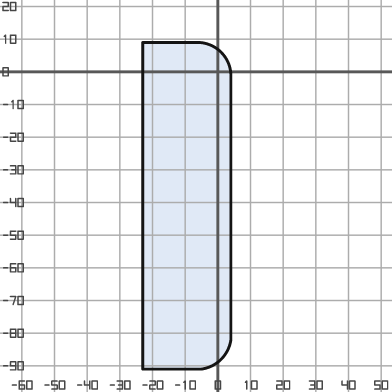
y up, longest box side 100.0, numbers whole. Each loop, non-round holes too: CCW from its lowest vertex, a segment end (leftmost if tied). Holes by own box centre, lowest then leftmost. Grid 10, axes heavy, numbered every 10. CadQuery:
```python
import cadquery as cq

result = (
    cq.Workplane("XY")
    .moveTo(-23.0, -91.0)
    .lineTo(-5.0, -91.0)
    .threePointArc((1.0, -88.0), (4.0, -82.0))
    .lineTo(4.0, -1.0)
    .threePointArc((1.0, 6.0), (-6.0, 9.0))
    .lineTo(-23.0, 9.0)
    .close()
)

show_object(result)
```